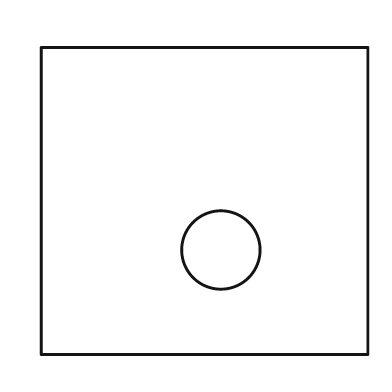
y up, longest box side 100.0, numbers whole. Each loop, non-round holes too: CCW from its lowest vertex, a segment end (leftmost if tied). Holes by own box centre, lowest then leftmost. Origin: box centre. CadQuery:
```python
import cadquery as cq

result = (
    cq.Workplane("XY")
    .moveTo(-50.0, -47.0)
    .lineTo(50.0, -47.0)
    .lineTo(50.0, 47.0)
    .lineTo(-50.0, 47.0)
    .close()
    .moveTo(5.0, -15.0)
    .circle(12.0)
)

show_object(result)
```